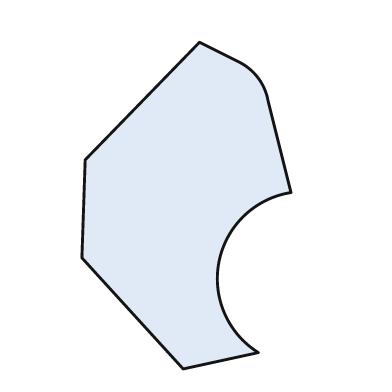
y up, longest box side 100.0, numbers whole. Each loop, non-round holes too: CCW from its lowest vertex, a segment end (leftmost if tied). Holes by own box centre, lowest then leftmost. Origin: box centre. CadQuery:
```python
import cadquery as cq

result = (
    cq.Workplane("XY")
    .moveTo(-1.0, -50.0)
    .lineTo(22.0, -45.0)
    .threePointArc((10.0, -17.0), (32.0, 4.0))
    .lineTo(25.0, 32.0)
    .threePointArc((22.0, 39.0), (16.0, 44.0))
    .lineTo(4.0, 50.0)
    .lineTo(-31.0, 14.0)
    .lineTo(-32.0, -16.0)
    .close()
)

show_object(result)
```